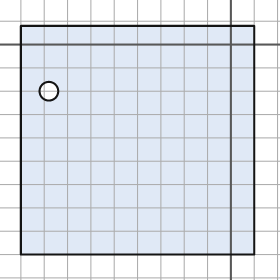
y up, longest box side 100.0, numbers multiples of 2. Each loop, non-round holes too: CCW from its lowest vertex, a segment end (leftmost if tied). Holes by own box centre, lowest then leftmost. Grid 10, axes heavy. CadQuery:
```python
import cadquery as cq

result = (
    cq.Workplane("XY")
    .moveTo(-90.0, -90.0)
    .lineTo(10.0, -90.0)
    .lineTo(10.0, 8.0)
    .lineTo(-90.0, 8.0)
    .close()
    .moveTo(-78.0, -20.0)
    .circle(4.0)
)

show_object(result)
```